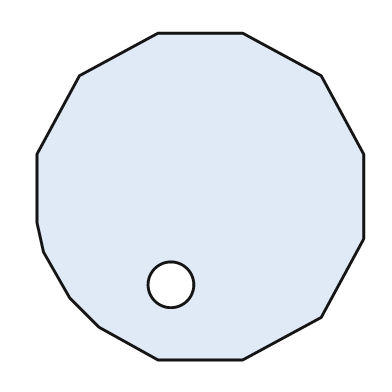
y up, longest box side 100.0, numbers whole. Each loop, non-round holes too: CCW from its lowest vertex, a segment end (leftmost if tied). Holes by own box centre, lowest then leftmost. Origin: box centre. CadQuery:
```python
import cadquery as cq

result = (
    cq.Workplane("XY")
    .moveTo(-13.0, -50.0)
    .lineTo(13.0, -50.0)
    .lineTo(37.0, -37.0)
    .lineTo(50.0, -13.0)
    .lineTo(50.0, 13.0)
    .lineTo(37.0, 37.0)
    .lineTo(13.0, 50.0)
    .lineTo(-13.0, 50.0)
    .lineTo(-37.0, 37.0)
    .lineTo(-50.0, 13.0)
    .lineTo(-50.0, -8.0)
    .lineTo(-48.0, -17.0)
    .lineTo(-40.0, -31.0)
    .lineTo(-31.0, -40.0)
    .close()
    .moveTo(-9.0, -27.0)
    .circle(7.0)
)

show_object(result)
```